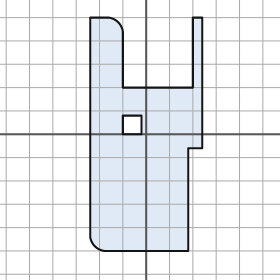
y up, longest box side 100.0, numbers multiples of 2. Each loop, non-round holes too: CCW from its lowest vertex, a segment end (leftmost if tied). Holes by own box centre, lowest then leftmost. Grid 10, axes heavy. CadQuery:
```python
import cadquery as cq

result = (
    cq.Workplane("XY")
    .moveTo(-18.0, -50.0)
    .lineTo(18.0, -50.0)
    .lineTo(18.0, -6.0)
    .lineTo(24.0, -6.0)
    .lineTo(24.0, 50.0)
    .lineTo(20.0, 50.0)
    .lineTo(20.0, 20.0)
    .lineTo(-10.0, 20.0)
    .lineTo(-10.0, 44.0)
    .threePointArc((-12.0, 48.0), (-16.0, 50.0))
    .lineTo(-24.0, 50.0)
    .lineTo(-24.0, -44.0)
    .threePointArc((-22.0, -48.0), (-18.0, -50.0))
    .close()
    .moveTo(-10.0, 0.0)
    .lineTo(-2.0, 0.0)
    .lineTo(-2.0, 8.0)
    .lineTo(-10.0, 8.0)
    .close()
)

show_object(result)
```